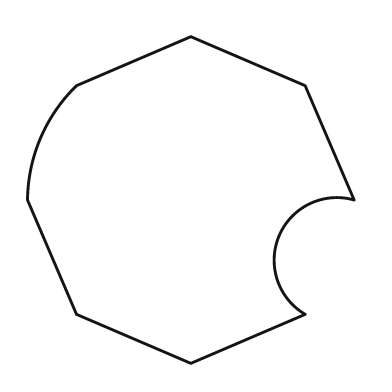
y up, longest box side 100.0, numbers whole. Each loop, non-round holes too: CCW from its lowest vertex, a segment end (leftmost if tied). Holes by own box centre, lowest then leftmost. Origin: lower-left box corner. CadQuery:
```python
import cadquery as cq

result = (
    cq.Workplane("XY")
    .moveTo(50.0, 0.0)
    .lineTo(85.0, 15.0)
    .threePointArc((77.0, 39.0), (100.0, 50.0))
    .lineTo(85.0, 85.0)
    .lineTo(50.0, 100.0)
    .lineTo(15.0, 85.0)
    .threePointArc((4.0, 69.0), (0.0, 50.0))
    .lineTo(15.0, 15.0)
    .close()
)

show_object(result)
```